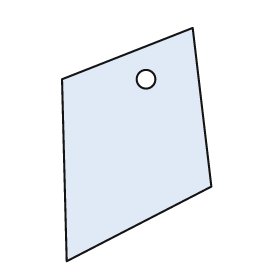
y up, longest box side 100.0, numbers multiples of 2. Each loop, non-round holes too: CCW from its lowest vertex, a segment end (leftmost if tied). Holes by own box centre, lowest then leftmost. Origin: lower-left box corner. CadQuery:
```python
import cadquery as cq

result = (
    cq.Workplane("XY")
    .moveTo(2.0, 0.0)
    .lineTo(64.0, 32.0)
    .lineTo(56.0, 100.0)
    .lineTo(0.0, 78.0)
    .close()
    .moveTo(36.0, 78.0)
    .circle(4.0)
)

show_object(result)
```